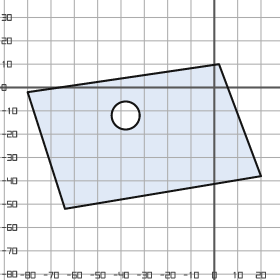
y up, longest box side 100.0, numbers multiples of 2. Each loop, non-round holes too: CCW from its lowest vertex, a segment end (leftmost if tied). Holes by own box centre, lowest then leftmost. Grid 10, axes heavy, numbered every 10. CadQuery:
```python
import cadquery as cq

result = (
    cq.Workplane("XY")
    .moveTo(-64.0, -52.0)
    .lineTo(20.0, -38.0)
    .lineTo(2.0, 10.0)
    .lineTo(-80.0, -2.0)
    .close()
    .moveTo(-38.0, -12.0)
    .circle(6.0)
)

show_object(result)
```